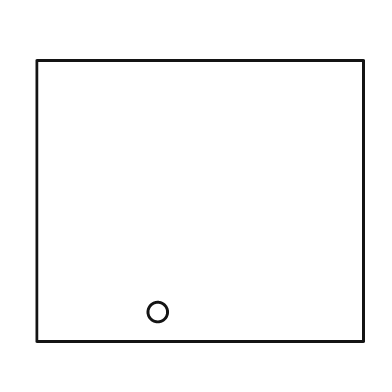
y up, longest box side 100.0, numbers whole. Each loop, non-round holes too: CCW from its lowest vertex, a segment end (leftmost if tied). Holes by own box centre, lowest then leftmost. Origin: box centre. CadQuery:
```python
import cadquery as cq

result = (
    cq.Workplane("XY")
    .moveTo(-50.0, -43.0)
    .lineTo(50.0, -43.0)
    .lineTo(50.0, 43.0)
    .lineTo(-50.0, 43.0)
    .close()
    .moveTo(-13.0, -34.0)
    .circle(3.0)
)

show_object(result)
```